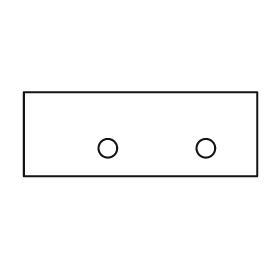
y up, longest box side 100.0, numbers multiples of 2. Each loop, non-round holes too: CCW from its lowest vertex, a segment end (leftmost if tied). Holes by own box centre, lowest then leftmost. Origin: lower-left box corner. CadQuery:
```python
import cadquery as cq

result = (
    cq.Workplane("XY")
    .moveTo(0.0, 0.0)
    .lineTo(100.0, 0.0)
    .lineTo(100.0, 36.0)
    .lineTo(0.0, 36.0)
    .close()
    .moveTo(36.0, 12.0)
    .circle(4.0)
    .moveTo(78.0, 12.0)
    .circle(4.0)
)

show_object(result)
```